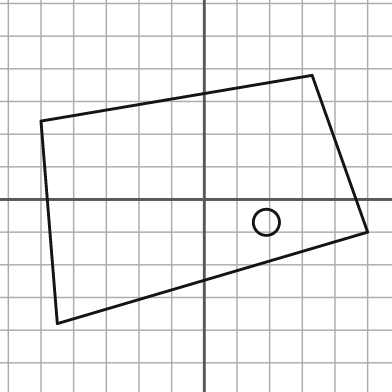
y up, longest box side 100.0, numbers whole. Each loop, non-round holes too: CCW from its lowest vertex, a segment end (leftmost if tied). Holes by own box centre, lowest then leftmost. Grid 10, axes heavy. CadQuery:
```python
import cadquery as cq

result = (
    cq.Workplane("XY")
    .moveTo(-45.0, -38.0)
    .lineTo(50.0, -10.0)
    .lineTo(33.0, 38.0)
    .lineTo(-50.0, 24.0)
    .close()
    .moveTo(19.0, -7.0)
    .circle(4.0)
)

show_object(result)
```